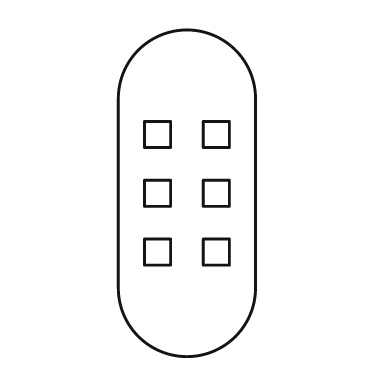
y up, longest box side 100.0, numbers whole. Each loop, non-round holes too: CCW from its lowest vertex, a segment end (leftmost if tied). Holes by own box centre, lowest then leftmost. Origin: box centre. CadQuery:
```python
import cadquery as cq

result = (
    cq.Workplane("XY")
    .moveTo(-21.0, -29.0)
    .threePointArc((0.0, -50.0), (21.0, -29.0))
    .lineTo(21.0, 29.0)
    .threePointArc((0.0, 50.0), (-21.0, 29.0))
    .close()
    .moveTo(-13.0, -22.0)
    .lineTo(-5.0, -22.0)
    .lineTo(-5.0, -14.0)
    .lineTo(-13.0, -14.0)
    .close()
    .moveTo(5.0, -22.0)
    .lineTo(13.0, -22.0)
    .lineTo(13.0, -14.0)
    .lineTo(5.0, -14.0)
    .close()
    .moveTo(-13.0, -4.0)
    .lineTo(-5.0, -4.0)
    .lineTo(-5.0, 4.0)
    .lineTo(-13.0, 4.0)
    .close()
    .moveTo(5.0, -4.0)
    .lineTo(13.0, -4.0)
    .lineTo(13.0, 4.0)
    .lineTo(5.0, 4.0)
    .close()
    .moveTo(-13.0, 14.0)
    .lineTo(-5.0, 14.0)
    .lineTo(-5.0, 22.0)
    .lineTo(-13.0, 22.0)
    .close()
    .moveTo(5.0, 14.0)
    .lineTo(13.0, 14.0)
    .lineTo(13.0, 22.0)
    .lineTo(5.0, 22.0)
    .close()
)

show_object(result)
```